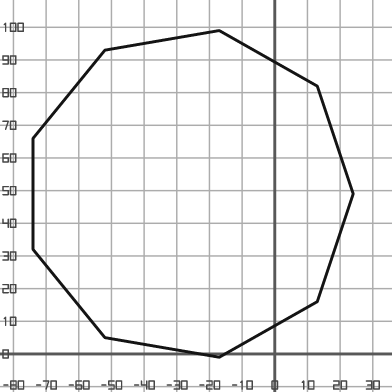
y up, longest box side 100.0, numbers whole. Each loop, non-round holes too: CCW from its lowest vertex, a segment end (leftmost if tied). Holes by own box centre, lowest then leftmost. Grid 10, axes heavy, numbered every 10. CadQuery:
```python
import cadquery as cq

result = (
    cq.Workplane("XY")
    .moveTo(-17.0, -1.0)
    .lineTo(13.0, 16.0)
    .lineTo(24.0, 49.0)
    .lineTo(13.0, 82.0)
    .lineTo(-17.0, 99.0)
    .lineTo(-52.0, 93.0)
    .lineTo(-74.0, 66.0)
    .lineTo(-74.0, 32.0)
    .lineTo(-52.0, 5.0)
    .close()
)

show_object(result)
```